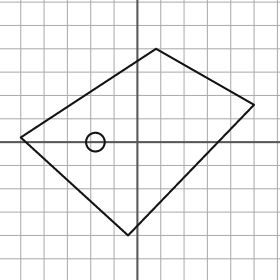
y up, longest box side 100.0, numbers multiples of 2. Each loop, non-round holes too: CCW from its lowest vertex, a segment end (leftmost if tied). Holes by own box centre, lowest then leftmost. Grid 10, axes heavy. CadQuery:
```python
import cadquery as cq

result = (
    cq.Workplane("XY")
    .moveTo(-4.0, -40.0)
    .lineTo(50.0, 16.0)
    .lineTo(8.0, 40.0)
    .lineTo(-50.0, 2.0)
    .close()
    .moveTo(-18.0, 0.0)
    .circle(4.0)
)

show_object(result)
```